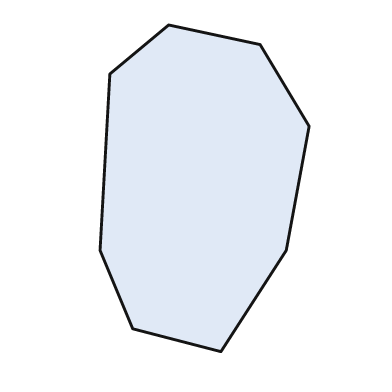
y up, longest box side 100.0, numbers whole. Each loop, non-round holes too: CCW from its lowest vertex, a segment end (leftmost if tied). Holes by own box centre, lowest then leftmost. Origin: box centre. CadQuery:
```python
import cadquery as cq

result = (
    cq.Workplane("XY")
    .moveTo(5.0, -50.0)
    .lineTo(25.0, -19.0)
    .lineTo(32.0, 19.0)
    .lineTo(17.0, 44.0)
    .lineTo(-11.0, 50.0)
    .lineTo(-29.0, 35.0)
    .lineTo(-32.0, -19.0)
    .lineTo(-22.0, -43.0)
    .close()
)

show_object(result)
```